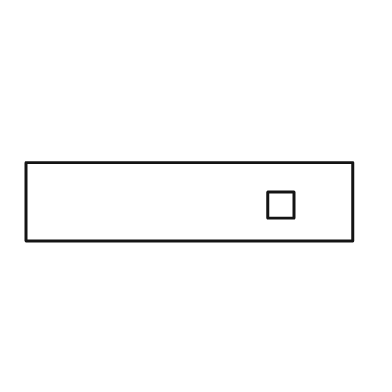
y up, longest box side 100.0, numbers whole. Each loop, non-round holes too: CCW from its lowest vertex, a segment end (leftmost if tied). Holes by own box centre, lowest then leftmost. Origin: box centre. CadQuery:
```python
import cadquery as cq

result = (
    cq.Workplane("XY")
    .moveTo(-50.0, -12.0)
    .lineTo(50.0, -12.0)
    .lineTo(50.0, 12.0)
    .lineTo(-50.0, 12.0)
    .close()
    .moveTo(24.0, -5.0)
    .lineTo(32.0, -5.0)
    .lineTo(32.0, 3.0)
    .lineTo(24.0, 3.0)
    .close()
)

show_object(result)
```